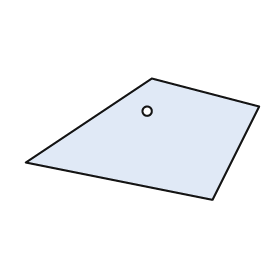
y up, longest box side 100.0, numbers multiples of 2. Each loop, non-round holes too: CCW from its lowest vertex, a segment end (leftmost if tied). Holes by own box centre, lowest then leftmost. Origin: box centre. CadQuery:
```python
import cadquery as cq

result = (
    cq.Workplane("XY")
    .moveTo(30.0, -26.0)
    .lineTo(50.0, 14.0)
    .lineTo(4.0, 26.0)
    .lineTo(-50.0, -10.0)
    .close()
    .moveTo(2.0, 12.0)
    .circle(2.0)
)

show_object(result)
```